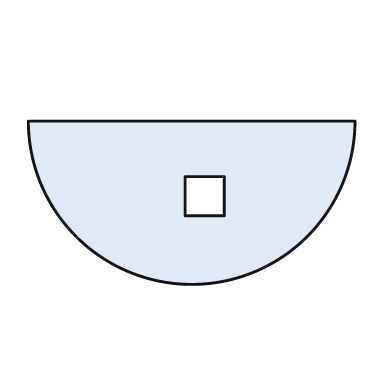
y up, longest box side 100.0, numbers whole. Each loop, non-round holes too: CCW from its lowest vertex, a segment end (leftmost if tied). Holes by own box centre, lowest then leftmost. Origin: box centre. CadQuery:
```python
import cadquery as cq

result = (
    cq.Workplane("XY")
    .moveTo(-50.0, 25.0)
    .threePointArc((0.0, -25.0), (50.0, 25.0))
    .close()
    .moveTo(-2.0, -4.0)
    .lineTo(10.0, -4.0)
    .lineTo(10.0, 8.0)
    .lineTo(-2.0, 8.0)
    .close()
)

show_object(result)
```